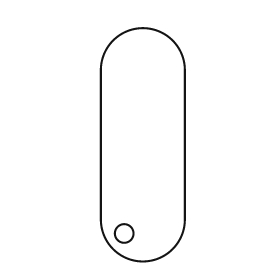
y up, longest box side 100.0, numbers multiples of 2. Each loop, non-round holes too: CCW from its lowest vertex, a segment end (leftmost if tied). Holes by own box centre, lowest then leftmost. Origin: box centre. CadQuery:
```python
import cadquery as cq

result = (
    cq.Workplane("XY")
    .moveTo(-18.0, -32.0)
    .threePointArc((0.0, -50.0), (18.0, -32.0))
    .lineTo(18.0, 32.0)
    .threePointArc((0.0, 50.0), (-18.0, 32.0))
    .close()
    .moveTo(-8.0, -38.0)
    .circle(4.0)
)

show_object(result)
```